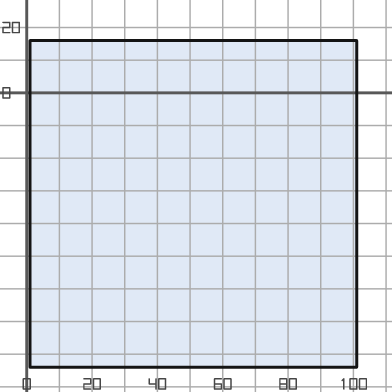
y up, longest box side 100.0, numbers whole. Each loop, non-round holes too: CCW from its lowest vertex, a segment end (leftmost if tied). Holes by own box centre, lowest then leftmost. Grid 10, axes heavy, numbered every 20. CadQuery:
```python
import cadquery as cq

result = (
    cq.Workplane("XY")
    .moveTo(1.0, -84.0)
    .lineTo(101.0, -84.0)
    .lineTo(101.0, 16.0)
    .lineTo(1.0, 16.0)
    .close()
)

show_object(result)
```